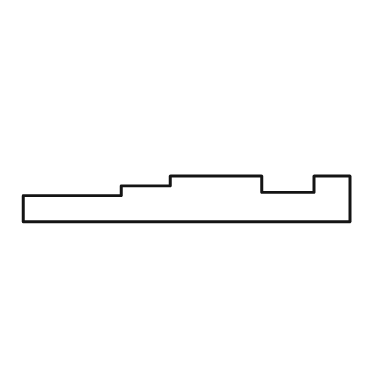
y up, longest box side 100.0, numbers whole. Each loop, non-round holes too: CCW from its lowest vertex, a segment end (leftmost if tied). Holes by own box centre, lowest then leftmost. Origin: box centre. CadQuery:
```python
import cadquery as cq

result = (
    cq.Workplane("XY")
    .moveTo(-50.0, -7.0)
    .lineTo(50.0, -7.0)
    .lineTo(50.0, 7.0)
    .lineTo(39.0, 7.0)
    .lineTo(39.0, 2.0)
    .lineTo(23.0, 2.0)
    .lineTo(23.0, 7.0)
    .lineTo(-5.0, 7.0)
    .lineTo(-5.0, 4.0)
    .lineTo(-20.0, 4.0)
    .lineTo(-20.0, 1.0)
    .lineTo(-50.0, 1.0)
    .close()
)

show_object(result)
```